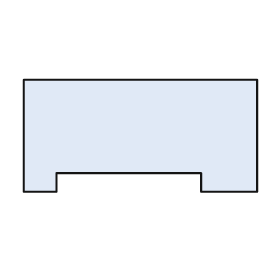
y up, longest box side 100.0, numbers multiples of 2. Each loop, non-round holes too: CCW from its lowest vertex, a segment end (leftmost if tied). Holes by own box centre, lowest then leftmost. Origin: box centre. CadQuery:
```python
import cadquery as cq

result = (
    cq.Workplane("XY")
    .moveTo(-50.0, -24.0)
    .lineTo(-36.0, -24.0)
    .lineTo(-36.0, -16.0)
    .lineTo(26.0, -16.0)
    .lineTo(26.0, -24.0)
    .lineTo(50.0, -24.0)
    .lineTo(50.0, 24.0)
    .lineTo(-50.0, 24.0)
    .close()
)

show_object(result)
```